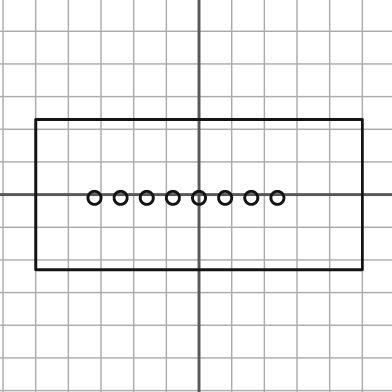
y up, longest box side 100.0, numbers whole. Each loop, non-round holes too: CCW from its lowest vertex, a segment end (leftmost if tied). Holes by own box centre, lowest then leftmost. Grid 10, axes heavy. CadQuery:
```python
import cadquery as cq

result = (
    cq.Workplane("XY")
    .moveTo(-50.0, -23.0)
    .lineTo(50.0, -23.0)
    .lineTo(50.0, 23.0)
    .lineTo(-50.0, 23.0)
    .close()
    .moveTo(-32.0, -1.0)
    .circle(2.0)
    .moveTo(-24.0, -1.0)
    .circle(2.0)
    .moveTo(-16.0, -1.0)
    .circle(2.0)
    .moveTo(-8.0, -1.0)
    .circle(2.0)
    .moveTo(0.0, -1.0)
    .circle(2.0)
    .moveTo(8.0, -1.0)
    .circle(2.0)
    .moveTo(16.0, -1.0)
    .circle(2.0)
    .moveTo(24.0, -1.0)
    .circle(2.0)
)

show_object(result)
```